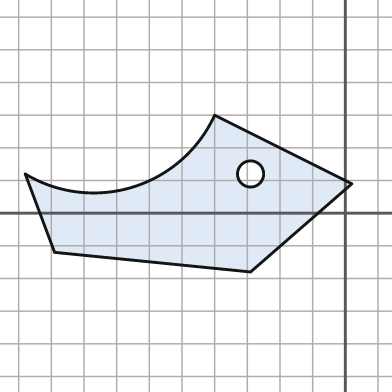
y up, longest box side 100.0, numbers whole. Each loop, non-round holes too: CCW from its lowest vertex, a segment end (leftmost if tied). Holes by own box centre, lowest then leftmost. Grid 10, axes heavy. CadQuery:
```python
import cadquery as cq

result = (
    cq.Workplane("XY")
    .moveTo(-29.0, -18.0)
    .lineTo(2.0, 9.0)
    .lineTo(-40.0, 30.0)
    .threePointArc((-65.0, 8.0), (-98.0, 12.0))
    .lineTo(-89.0, -12.0)
    .close()
    .moveTo(-29.0, 12.0)
    .circle(4.0)
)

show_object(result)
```